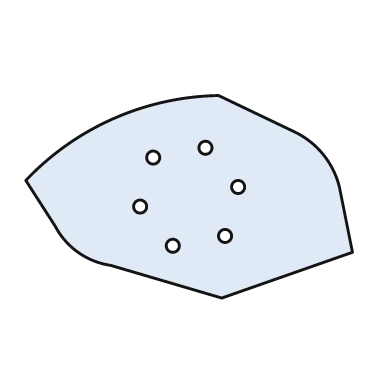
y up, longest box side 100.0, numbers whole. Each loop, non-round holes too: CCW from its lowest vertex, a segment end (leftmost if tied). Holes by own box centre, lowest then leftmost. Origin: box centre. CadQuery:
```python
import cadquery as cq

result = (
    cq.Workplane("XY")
    .moveTo(10.0, -31.0)
    .lineTo(50.0, -17.0)
    .lineTo(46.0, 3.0)
    .threePointArc((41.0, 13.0), (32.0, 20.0))
    .lineTo(9.0, 31.0)
    .threePointArc((-23.0, 24.0), (-50.0, 5.0))
    .lineTo(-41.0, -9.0)
    .threePointArc((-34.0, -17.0), (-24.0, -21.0))
    .close()
    .moveTo(-5.0, -15.0)
    .circle(2.0)
    .moveTo(11.0, -12.0)
    .circle(2.0)
    .moveTo(-15.0, -3.0)
    .circle(2.0)
    .moveTo(15.0, 3.0)
    .circle(2.0)
    .moveTo(-11.0, 12.0)
    .circle(2.0)
    .moveTo(5.0, 15.0)
    .circle(2.0)
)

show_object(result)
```